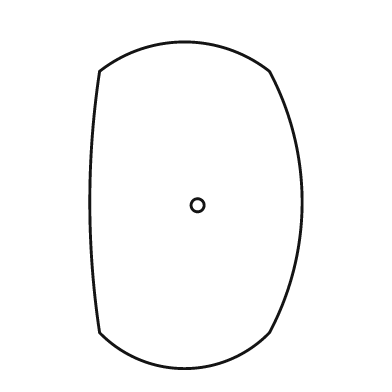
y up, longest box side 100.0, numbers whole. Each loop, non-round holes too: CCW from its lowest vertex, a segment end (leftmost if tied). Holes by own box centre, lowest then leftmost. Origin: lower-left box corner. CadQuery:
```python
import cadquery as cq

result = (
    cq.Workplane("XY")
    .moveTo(3.0, 11.0)
    .threePointArc((29.0, 0.0), (55.0, 11.0))
    .threePointArc((65.0, 51.0), (55.0, 91.0))
    .threePointArc((29.0, 100.0), (3.0, 91.0))
    .threePointArc((0.0, 51.0), (3.0, 11.0))
    .close()
    .moveTo(33.0, 50.0)
    .circle(2.0)
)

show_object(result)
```